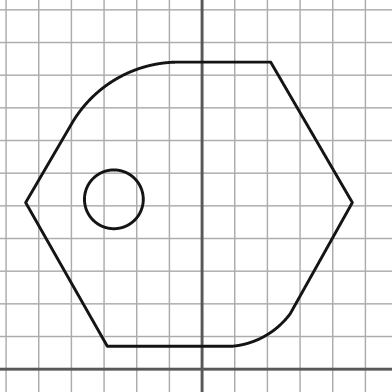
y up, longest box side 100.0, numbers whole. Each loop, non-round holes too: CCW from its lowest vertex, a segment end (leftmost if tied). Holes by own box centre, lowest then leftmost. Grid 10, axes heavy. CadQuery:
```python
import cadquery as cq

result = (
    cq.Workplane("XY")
    .moveTo(-29.0, 7.0)
    .lineTo(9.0, 7.0)
    .threePointArc((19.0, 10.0), (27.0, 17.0))
    .lineTo(46.0, 51.0)
    .lineTo(21.0, 94.0)
    .lineTo(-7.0, 94.0)
    .threePointArc((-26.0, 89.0), (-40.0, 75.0))
    .lineTo(-54.0, 51.0)
    .close()
    .moveTo(-27.0, 52.0)
    .circle(9.0)
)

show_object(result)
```